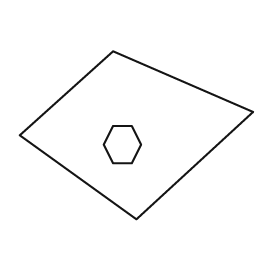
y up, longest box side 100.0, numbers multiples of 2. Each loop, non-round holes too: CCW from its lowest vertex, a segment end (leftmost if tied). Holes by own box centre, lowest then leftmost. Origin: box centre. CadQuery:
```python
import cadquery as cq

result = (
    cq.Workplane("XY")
    .moveTo(0.0, -36.0)
    .lineTo(50.0, 10.0)
    .lineTo(-10.0, 36.0)
    .lineTo(-50.0, 0.0)
    .close()
    .moveTo(-10.0, -12.0)
    .lineTo(-2.0, -12.0)
    .lineTo(2.0, -4.0)
    .lineTo(-2.0, 4.0)
    .lineTo(-10.0, 4.0)
    .lineTo(-14.0, -4.0)
    .close()
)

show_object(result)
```